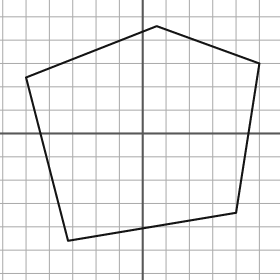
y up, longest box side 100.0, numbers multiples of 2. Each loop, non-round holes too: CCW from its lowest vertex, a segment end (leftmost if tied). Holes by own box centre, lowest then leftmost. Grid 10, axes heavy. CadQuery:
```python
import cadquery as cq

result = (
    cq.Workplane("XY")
    .moveTo(-32.0, -46.0)
    .lineTo(40.0, -34.0)
    .lineTo(50.0, 30.0)
    .lineTo(6.0, 46.0)
    .lineTo(-50.0, 24.0)
    .close()
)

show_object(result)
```